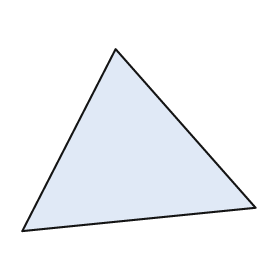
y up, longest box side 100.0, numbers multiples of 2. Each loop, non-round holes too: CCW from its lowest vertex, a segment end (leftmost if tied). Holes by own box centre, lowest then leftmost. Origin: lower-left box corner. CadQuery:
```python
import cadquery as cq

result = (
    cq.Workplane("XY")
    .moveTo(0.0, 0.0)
    .lineTo(100.0, 10.0)
    .lineTo(40.0, 78.0)
    .close()
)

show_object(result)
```